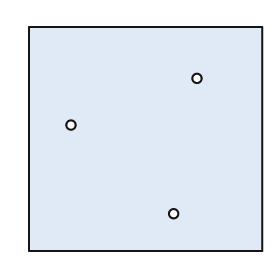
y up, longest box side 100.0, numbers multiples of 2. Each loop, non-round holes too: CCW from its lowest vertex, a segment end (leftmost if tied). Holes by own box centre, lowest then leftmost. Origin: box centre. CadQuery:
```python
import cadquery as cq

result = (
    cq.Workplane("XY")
    .moveTo(-50.0, -48.0)
    .lineTo(50.0, -48.0)
    .lineTo(50.0, 48.0)
    .lineTo(-50.0, 48.0)
    .close()
    .moveTo(12.0, -32.0)
    .circle(2.0)
    .moveTo(-32.0, 6.0)
    .circle(2.0)
    .moveTo(22.0, 26.0)
    .circle(2.0)
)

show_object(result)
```